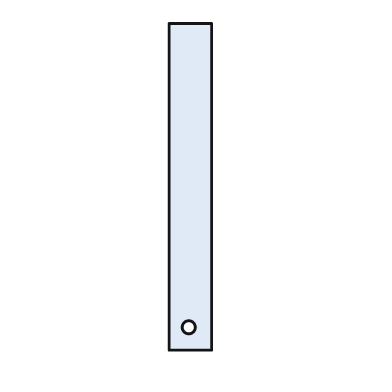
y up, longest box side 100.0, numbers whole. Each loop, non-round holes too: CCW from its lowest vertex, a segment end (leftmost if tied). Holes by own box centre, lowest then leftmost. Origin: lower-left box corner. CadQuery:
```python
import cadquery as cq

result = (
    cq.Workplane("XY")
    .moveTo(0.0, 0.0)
    .lineTo(13.0, 0.0)
    .lineTo(13.0, 100.0)
    .lineTo(0.0, 100.0)
    .close()
    .moveTo(6.0, 7.0)
    .circle(2.0)
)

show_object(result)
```